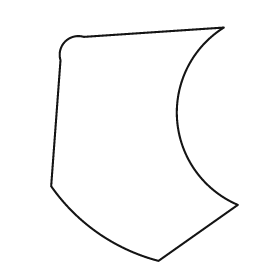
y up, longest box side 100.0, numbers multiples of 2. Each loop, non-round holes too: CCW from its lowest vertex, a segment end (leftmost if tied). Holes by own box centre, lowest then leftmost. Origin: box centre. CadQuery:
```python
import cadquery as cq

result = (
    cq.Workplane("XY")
    .moveTo(6.0, -50.0)
    .lineTo(40.0, -26.0)
    .threePointArc((14.0, 10.0), (34.0, 50.0))
    .lineTo(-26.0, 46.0)
    .threePointArc((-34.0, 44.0), (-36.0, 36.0))
    .lineTo(-40.0, -18.0)
    .threePointArc((-20.0, -38.0), (6.0, -50.0))
    .close()
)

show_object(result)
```